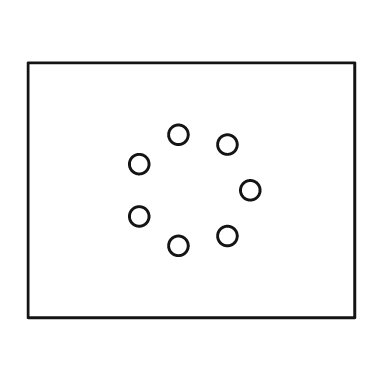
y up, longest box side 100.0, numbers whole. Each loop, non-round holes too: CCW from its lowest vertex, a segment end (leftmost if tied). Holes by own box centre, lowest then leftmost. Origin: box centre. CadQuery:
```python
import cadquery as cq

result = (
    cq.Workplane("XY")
    .moveTo(-50.0, -39.0)
    .lineTo(50.0, -39.0)
    .lineTo(50.0, 39.0)
    .lineTo(-50.0, 39.0)
    .close()
    .moveTo(-4.0, -17.0)
    .circle(3.0)
    .moveTo(11.0, -14.0)
    .circle(3.0)
    .moveTo(-16.0, -8.0)
    .circle(3.0)
    .moveTo(18.0, 0.0)
    .circle(3.0)
    .moveTo(-16.0, 8.0)
    .circle(3.0)
    .moveTo(11.0, 14.0)
    .circle(3.0)
    .moveTo(-4.0, 17.0)
    .circle(3.0)
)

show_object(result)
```